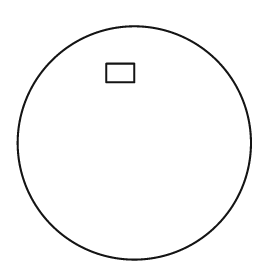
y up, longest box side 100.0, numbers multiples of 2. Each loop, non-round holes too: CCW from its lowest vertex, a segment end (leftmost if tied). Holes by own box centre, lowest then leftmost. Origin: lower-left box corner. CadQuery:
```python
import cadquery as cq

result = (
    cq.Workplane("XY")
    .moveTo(50.0, 50.0)
    .circle(50.0)
    .moveTo(38.0, 76.0)
    .lineTo(50.0, 76.0)
    .lineTo(50.0, 84.0)
    .lineTo(38.0, 84.0)
    .close()
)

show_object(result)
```